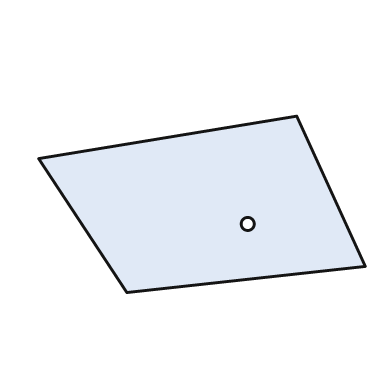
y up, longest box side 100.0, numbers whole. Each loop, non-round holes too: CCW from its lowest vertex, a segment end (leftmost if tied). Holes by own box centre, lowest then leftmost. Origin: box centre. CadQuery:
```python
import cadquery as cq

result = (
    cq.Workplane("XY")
    .moveTo(-23.0, -27.0)
    .lineTo(50.0, -19.0)
    .lineTo(29.0, 27.0)
    .lineTo(-50.0, 14.0)
    .close()
    .moveTo(14.0, -6.0)
    .circle(2.0)
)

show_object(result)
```